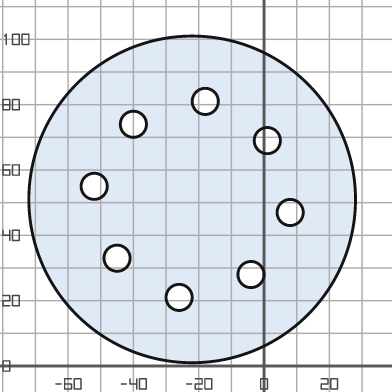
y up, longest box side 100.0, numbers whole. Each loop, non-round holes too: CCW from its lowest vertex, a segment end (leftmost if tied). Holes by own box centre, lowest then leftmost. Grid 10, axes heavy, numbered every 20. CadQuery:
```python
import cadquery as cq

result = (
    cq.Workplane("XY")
    .moveTo(-22.0, 51.0)
    .circle(50.0)
    .moveTo(-26.0, 21.0)
    .circle(4.0)
    .moveTo(-4.0, 28.0)
    .circle(4.0)
    .moveTo(-45.0, 33.0)
    .circle(4.0)
    .moveTo(8.0, 47.0)
    .circle(4.0)
    .moveTo(-52.0, 55.0)
    .circle(4.0)
    .moveTo(1.0, 69.0)
    .circle(4.0)
    .moveTo(-40.0, 74.0)
    .circle(4.0)
    .moveTo(-18.0, 81.0)
    .circle(4.0)
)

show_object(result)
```